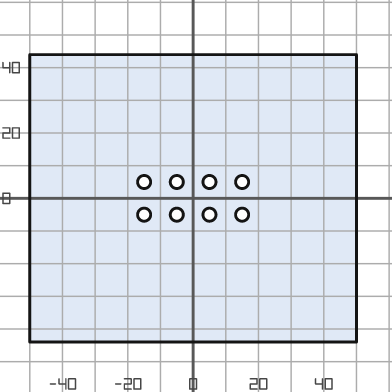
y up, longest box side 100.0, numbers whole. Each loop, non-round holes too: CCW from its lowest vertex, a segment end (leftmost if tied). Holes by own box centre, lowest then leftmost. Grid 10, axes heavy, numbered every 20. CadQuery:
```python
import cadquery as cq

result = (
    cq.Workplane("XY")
    .moveTo(-50.0, -44.0)
    .lineTo(50.0, -44.0)
    .lineTo(50.0, 44.0)
    .lineTo(-50.0, 44.0)
    .close()
    .moveTo(-15.0, -5.0)
    .circle(2.0)
    .moveTo(-5.0, -5.0)
    .circle(2.0)
    .moveTo(5.0, -5.0)
    .circle(2.0)
    .moveTo(15.0, -5.0)
    .circle(2.0)
    .moveTo(-15.0, 5.0)
    .circle(2.0)
    .moveTo(-5.0, 5.0)
    .circle(2.0)
    .moveTo(5.0, 5.0)
    .circle(2.0)
    .moveTo(15.0, 5.0)
    .circle(2.0)
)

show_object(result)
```